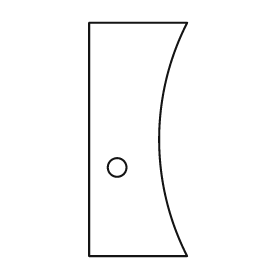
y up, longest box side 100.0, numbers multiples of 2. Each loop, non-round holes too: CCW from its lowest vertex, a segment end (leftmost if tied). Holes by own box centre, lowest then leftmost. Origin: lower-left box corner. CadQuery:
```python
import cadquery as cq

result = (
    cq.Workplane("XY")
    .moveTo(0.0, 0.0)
    .lineTo(42.0, 0.0)
    .threePointArc((30.0, 50.0), (42.0, 100.0))
    .lineTo(0.0, 100.0)
    .close()
    .moveTo(12.0, 38.0)
    .circle(4.0)
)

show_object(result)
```